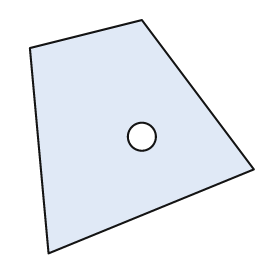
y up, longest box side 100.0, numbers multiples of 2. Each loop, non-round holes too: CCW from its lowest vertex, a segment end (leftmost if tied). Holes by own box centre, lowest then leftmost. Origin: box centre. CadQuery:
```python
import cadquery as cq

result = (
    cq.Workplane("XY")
    .moveTo(-40.0, -50.0)
    .lineTo(48.0, -14.0)
    .lineTo(0.0, 50.0)
    .lineTo(-48.0, 38.0)
    .close()
    .moveTo(0.0, 0.0)
    .circle(6.0)
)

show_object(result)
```